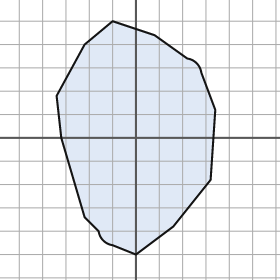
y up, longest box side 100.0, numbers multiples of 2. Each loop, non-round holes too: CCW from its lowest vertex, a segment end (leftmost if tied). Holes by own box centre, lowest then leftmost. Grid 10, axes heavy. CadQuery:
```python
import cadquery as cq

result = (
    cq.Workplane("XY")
    .moveTo(0.0, -50.0)
    .lineTo(16.0, -38.0)
    .lineTo(32.0, -18.0)
    .lineTo(34.0, 12.0)
    .lineTo(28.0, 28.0)
    .threePointArc((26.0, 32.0), (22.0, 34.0))
    .lineTo(8.0, 44.0)
    .lineTo(-10.0, 50.0)
    .lineTo(-22.0, 40.0)
    .lineTo(-34.0, 18.0)
    .lineTo(-32.0, 0.0)
    .lineTo(-22.0, -34.0)
    .lineTo(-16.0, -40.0)
    .threePointArc((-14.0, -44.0), (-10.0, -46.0))
    .close()
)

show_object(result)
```